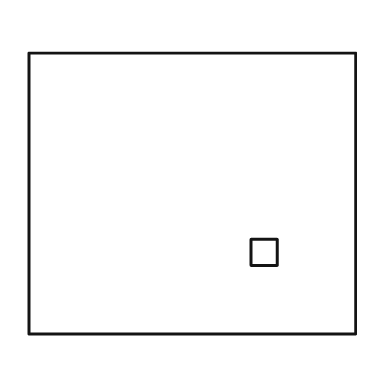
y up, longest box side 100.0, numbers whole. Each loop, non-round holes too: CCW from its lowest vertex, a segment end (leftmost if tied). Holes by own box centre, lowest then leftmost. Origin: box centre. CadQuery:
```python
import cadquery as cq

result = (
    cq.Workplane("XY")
    .moveTo(-50.0, -43.0)
    .lineTo(50.0, -43.0)
    .lineTo(50.0, 43.0)
    .lineTo(-50.0, 43.0)
    .close()
    .moveTo(18.0, -22.0)
    .lineTo(26.0, -22.0)
    .lineTo(26.0, -14.0)
    .lineTo(18.0, -14.0)
    .close()
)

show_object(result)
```